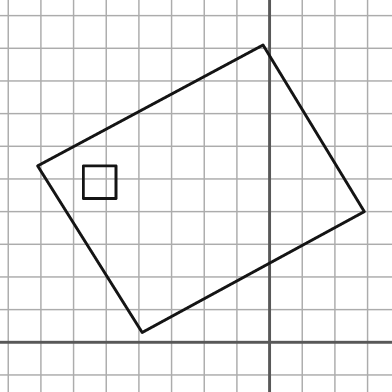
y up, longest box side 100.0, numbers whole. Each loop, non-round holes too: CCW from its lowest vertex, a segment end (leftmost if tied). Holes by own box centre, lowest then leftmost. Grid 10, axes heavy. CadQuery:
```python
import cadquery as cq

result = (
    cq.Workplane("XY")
    .moveTo(-39.0, 3.0)
    .lineTo(29.0, 40.0)
    .lineTo(-2.0, 91.0)
    .lineTo(-71.0, 54.0)
    .close()
    .moveTo(-57.0, 44.0)
    .lineTo(-47.0, 44.0)
    .lineTo(-47.0, 54.0)
    .lineTo(-57.0, 54.0)
    .close()
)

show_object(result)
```